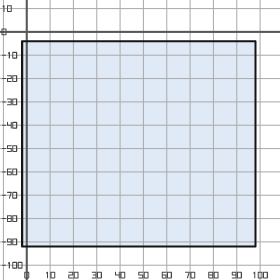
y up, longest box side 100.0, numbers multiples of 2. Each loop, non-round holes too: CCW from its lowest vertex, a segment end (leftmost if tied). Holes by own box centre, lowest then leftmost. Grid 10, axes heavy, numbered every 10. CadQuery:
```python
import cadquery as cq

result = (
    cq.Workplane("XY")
    .moveTo(-2.0, -92.0)
    .lineTo(98.0, -92.0)
    .lineTo(98.0, -4.0)
    .lineTo(-2.0, -4.0)
    .close()
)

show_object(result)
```